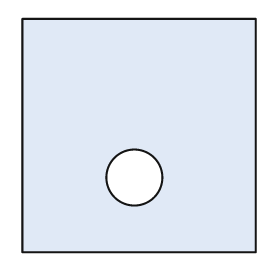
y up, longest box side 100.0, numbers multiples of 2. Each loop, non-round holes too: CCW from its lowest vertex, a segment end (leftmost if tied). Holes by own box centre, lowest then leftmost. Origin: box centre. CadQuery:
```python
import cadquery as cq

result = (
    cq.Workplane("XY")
    .moveTo(-50.0, -50.0)
    .lineTo(50.0, -50.0)
    .lineTo(50.0, 50.0)
    .lineTo(-50.0, 50.0)
    .close()
    .moveTo(-2.0, -18.0)
    .circle(12.0)
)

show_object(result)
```